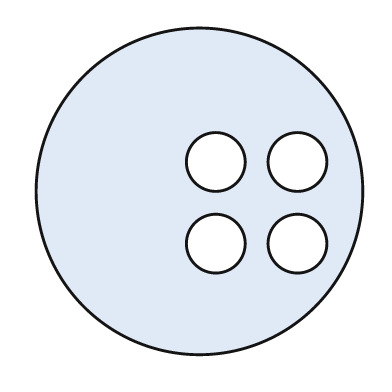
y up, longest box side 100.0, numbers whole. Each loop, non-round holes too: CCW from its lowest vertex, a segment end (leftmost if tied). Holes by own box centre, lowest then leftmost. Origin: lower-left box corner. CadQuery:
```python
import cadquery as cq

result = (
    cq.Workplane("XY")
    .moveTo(50.0, 50.0)
    .circle(50.0)
    .moveTo(55.0, 34.0)
    .circle(9.0)
    .moveTo(80.0, 34.0)
    .circle(9.0)
    .moveTo(55.0, 59.0)
    .circle(9.0)
    .moveTo(80.0, 59.0)
    .circle(9.0)
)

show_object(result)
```